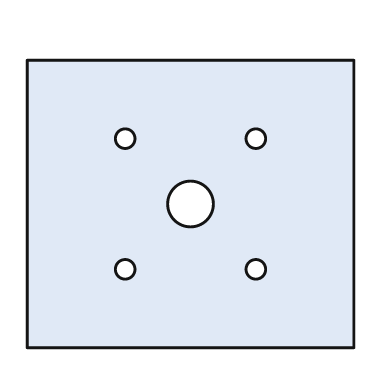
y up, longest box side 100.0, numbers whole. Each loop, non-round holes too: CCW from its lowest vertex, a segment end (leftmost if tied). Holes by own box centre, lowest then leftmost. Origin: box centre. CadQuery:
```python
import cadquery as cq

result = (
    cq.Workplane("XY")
    .moveTo(-50.0, -44.0)
    .lineTo(50.0, -44.0)
    .lineTo(50.0, 44.0)
    .lineTo(-50.0, 44.0)
    .close()
    .moveTo(-20.0, -20.0)
    .circle(3.0)
    .moveTo(20.0, -20.0)
    .circle(3.0)
    .moveTo(0.0, 0.0)
    .circle(7.0)
    .moveTo(-20.0, 20.0)
    .circle(3.0)
    .moveTo(20.0, 20.0)
    .circle(3.0)
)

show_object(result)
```